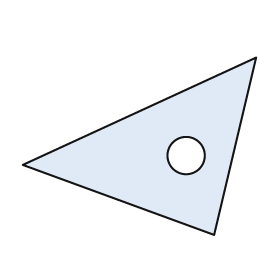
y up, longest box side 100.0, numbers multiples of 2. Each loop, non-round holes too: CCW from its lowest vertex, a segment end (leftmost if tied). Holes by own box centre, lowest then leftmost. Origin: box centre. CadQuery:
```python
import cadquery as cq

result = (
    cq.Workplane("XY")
    .moveTo(32.0, -38.0)
    .lineTo(50.0, 38.0)
    .lineTo(-50.0, -8.0)
    .close()
    .moveTo(20.0, -4.0)
    .circle(8.0)
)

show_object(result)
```